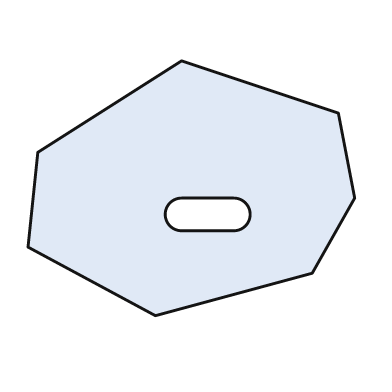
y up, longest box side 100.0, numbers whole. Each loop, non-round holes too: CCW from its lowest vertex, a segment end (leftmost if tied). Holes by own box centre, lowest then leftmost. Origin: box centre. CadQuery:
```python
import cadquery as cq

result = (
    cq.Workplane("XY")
    .moveTo(-11.0, -39.0)
    .lineTo(37.0, -26.0)
    .lineTo(50.0, -3.0)
    .lineTo(45.0, 23.0)
    .lineTo(-3.0, 39.0)
    .lineTo(-47.0, 11.0)
    .lineTo(-50.0, -18.0)
    .close()
    .moveTo(-3.0, -13.0)
    .lineTo(13.0, -13.0)
    .threePointArc((18.0, -8.0), (13.0, -3.0))
    .lineTo(-3.0, -3.0)
    .threePointArc((-8.0, -8.0), (-3.0, -13.0))
    .close()
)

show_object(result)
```